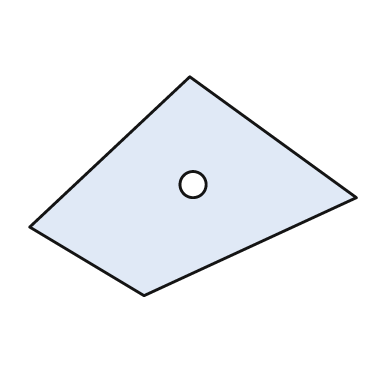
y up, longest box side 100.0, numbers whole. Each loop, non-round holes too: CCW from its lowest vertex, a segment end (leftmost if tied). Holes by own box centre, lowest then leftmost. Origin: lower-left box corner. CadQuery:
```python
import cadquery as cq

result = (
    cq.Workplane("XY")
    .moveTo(35.0, 0.0)
    .lineTo(100.0, 30.0)
    .lineTo(49.0, 67.0)
    .lineTo(0.0, 21.0)
    .close()
    .moveTo(50.0, 34.0)
    .circle(4.0)
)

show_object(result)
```